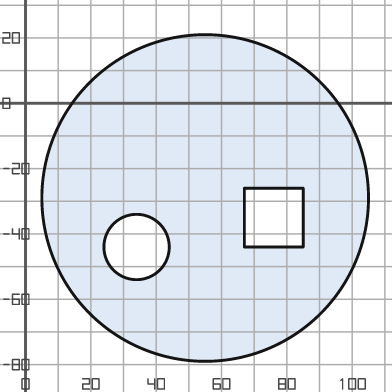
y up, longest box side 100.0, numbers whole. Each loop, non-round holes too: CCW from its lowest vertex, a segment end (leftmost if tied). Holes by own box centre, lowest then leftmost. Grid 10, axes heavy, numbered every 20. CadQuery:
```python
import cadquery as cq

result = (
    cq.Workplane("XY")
    .moveTo(55.0, -29.0)
    .circle(50.0)
    .moveTo(34.0, -44.0)
    .circle(10.0)
    .moveTo(67.0, -44.0)
    .lineTo(85.0, -44.0)
    .lineTo(85.0, -26.0)
    .lineTo(67.0, -26.0)
    .close()
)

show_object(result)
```